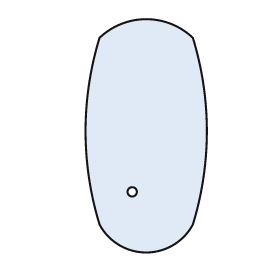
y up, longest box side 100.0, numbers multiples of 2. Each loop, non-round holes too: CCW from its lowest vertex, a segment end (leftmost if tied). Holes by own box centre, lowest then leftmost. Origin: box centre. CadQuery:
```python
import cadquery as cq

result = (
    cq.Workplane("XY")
    .moveTo(-20.0, -38.0)
    .threePointArc((0.0, -50.0), (20.0, -38.0))
    .threePointArc((26.0, 2.0), (20.0, 42.0))
    .threePointArc((0.0, 50.0), (-20.0, 42.0))
    .threePointArc((-26.0, 2.0), (-20.0, -38.0))
    .close()
    .moveTo(-6.0, -24.0)
    .circle(2.0)
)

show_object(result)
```